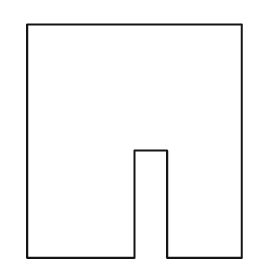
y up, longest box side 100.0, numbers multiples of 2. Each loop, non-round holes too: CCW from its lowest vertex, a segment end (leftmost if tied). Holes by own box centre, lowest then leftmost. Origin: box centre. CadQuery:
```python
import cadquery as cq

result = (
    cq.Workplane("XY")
    .moveTo(-46.0, -50.0)
    .lineTo(0.0, -50.0)
    .lineTo(0.0, -4.0)
    .lineTo(14.0, -4.0)
    .lineTo(14.0, -50.0)
    .lineTo(46.0, -50.0)
    .lineTo(46.0, 50.0)
    .lineTo(-46.0, 50.0)
    .close()
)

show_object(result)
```